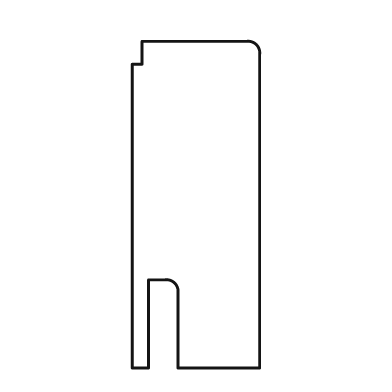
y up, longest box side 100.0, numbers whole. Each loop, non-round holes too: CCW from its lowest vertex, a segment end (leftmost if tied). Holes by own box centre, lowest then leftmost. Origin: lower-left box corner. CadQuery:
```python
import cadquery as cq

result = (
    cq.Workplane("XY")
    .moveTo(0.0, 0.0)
    .lineTo(5.0, 0.0)
    .lineTo(5.0, 27.0)
    .lineTo(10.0, 27.0)
    .threePointArc((13.0, 26.0), (14.0, 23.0))
    .lineTo(14.0, 0.0)
    .lineTo(39.0, 0.0)
    .lineTo(39.0, 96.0)
    .threePointArc((38.0, 99.0), (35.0, 100.0))
    .lineTo(3.0, 100.0)
    .lineTo(3.0, 93.0)
    .lineTo(0.0, 93.0)
    .close()
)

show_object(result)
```